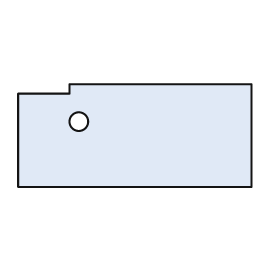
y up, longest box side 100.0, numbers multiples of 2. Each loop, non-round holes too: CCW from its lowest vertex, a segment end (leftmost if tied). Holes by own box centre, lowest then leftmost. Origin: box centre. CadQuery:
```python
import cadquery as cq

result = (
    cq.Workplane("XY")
    .moveTo(-50.0, -22.0)
    .lineTo(50.0, -22.0)
    .lineTo(50.0, 22.0)
    .lineTo(-28.0, 22.0)
    .lineTo(-28.0, 18.0)
    .lineTo(-50.0, 18.0)
    .close()
    .moveTo(-24.0, 6.0)
    .circle(4.0)
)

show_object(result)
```